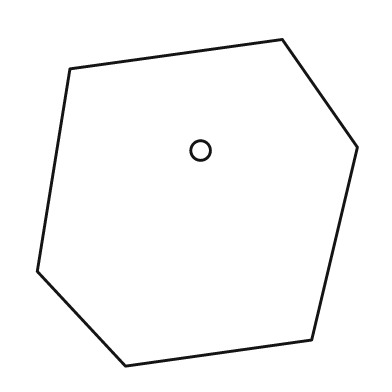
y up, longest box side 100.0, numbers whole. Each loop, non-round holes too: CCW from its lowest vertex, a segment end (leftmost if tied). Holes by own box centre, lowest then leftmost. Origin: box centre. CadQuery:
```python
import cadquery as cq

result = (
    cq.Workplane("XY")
    .moveTo(-22.0, -50.0)
    .lineTo(35.0, -42.0)
    .lineTo(49.0, 17.0)
    .lineTo(26.0, 50.0)
    .lineTo(-39.0, 41.0)
    .lineTo(-49.0, -21.0)
    .close()
    .moveTo(1.0, 16.0)
    .circle(3.0)
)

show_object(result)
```